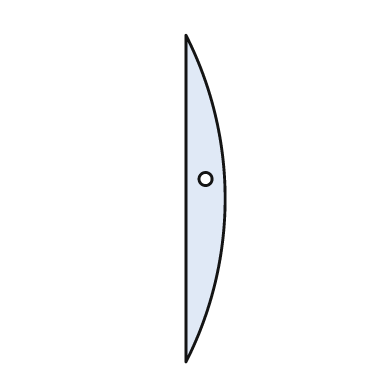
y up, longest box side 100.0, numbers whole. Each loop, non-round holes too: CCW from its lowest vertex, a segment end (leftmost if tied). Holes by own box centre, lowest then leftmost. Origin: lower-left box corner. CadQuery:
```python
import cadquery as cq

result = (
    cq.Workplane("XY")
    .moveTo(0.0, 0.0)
    .threePointArc((12.0, 50.0), (0.0, 100.0))
    .close()
    .moveTo(6.0, 56.0)
    .circle(2.0)
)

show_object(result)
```